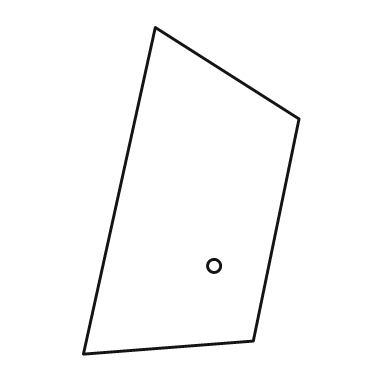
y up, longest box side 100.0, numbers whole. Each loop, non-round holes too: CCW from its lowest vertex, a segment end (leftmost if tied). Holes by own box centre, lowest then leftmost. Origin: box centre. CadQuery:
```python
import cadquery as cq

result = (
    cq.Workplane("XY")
    .moveTo(-33.0, -50.0)
    .lineTo(19.0, -46.0)
    .lineTo(33.0, 22.0)
    .lineTo(-11.0, 50.0)
    .close()
    .moveTo(7.0, -23.0)
    .circle(2.0)
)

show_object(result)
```